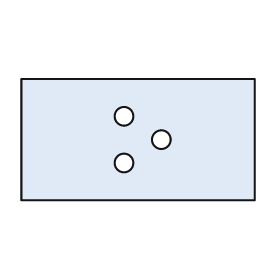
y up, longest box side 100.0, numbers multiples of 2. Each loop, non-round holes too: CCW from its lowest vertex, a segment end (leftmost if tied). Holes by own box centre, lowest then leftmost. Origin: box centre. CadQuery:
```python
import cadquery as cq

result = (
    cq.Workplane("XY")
    .moveTo(-50.0, -26.0)
    .lineTo(50.0, -26.0)
    .lineTo(50.0, 26.0)
    .lineTo(-50.0, 26.0)
    .close()
    .moveTo(-6.0, -10.0)
    .circle(4.0)
    .moveTo(10.0, 0.0)
    .circle(4.0)
    .moveTo(-6.0, 10.0)
    .circle(4.0)
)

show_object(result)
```